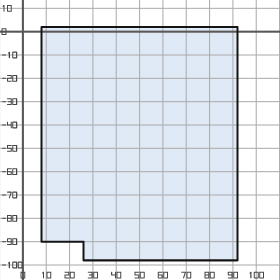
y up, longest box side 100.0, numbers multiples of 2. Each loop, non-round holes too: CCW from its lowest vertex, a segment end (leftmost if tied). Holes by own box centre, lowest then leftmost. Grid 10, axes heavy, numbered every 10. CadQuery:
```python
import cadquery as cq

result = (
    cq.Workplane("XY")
    .moveTo(26.0, -98.0)
    .lineTo(92.0, -98.0)
    .lineTo(92.0, 2.0)
    .lineTo(8.0, 2.0)
    .lineTo(8.0, -90.0)
    .lineTo(26.0, -90.0)
    .close()
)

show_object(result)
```